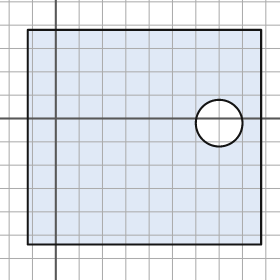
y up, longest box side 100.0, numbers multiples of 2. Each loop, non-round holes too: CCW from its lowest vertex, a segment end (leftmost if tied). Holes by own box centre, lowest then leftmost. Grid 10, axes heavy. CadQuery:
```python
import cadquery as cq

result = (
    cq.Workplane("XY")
    .moveTo(-12.0, -54.0)
    .lineTo(88.0, -54.0)
    .lineTo(88.0, 38.0)
    .lineTo(-12.0, 38.0)
    .close()
    .moveTo(70.0, -2.0)
    .circle(10.0)
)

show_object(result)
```